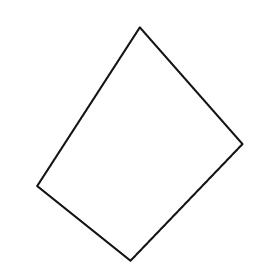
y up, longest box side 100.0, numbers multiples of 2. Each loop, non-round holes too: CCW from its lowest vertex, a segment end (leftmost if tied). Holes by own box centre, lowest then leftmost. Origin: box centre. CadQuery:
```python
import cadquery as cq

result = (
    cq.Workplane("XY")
    .moveTo(-4.0, -50.0)
    .lineTo(44.0, 0.0)
    .lineTo(0.0, 50.0)
    .lineTo(-44.0, -18.0)
    .close()
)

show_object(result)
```